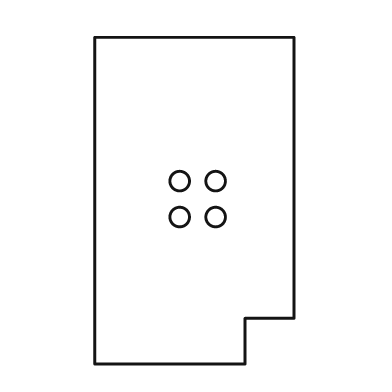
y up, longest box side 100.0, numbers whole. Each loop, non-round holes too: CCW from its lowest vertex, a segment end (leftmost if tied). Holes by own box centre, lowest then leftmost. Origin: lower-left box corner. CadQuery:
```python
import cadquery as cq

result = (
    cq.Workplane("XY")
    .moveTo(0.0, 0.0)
    .lineTo(46.0, 0.0)
    .lineTo(46.0, 14.0)
    .lineTo(61.0, 14.0)
    .lineTo(61.0, 100.0)
    .lineTo(0.0, 100.0)
    .close()
    .moveTo(26.0, 45.0)
    .circle(3.0)
    .moveTo(37.0, 45.0)
    .circle(3.0)
    .moveTo(26.0, 56.0)
    .circle(3.0)
    .moveTo(37.0, 56.0)
    .circle(3.0)
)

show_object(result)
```